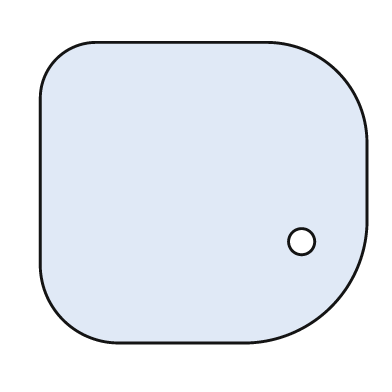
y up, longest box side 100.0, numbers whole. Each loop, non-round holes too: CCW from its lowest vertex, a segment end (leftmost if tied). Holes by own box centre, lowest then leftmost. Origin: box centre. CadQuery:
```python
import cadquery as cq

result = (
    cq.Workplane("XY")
    .moveTo(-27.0, -46.0)
    .lineTo(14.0, -46.0)
    .threePointArc((39.0, -35.0), (50.0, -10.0))
    .lineTo(50.0, 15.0)
    .threePointArc((41.0, 37.0), (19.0, 46.0))
    .lineTo(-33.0, 46.0)
    .threePointArc((-45.0, 41.0), (-50.0, 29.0))
    .lineTo(-50.0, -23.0)
    .threePointArc((-43.0, -39.0), (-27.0, -46.0))
    .close()
    .moveTo(30.0, -15.0)
    .circle(4.0)
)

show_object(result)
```